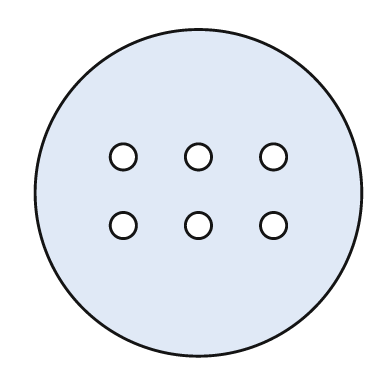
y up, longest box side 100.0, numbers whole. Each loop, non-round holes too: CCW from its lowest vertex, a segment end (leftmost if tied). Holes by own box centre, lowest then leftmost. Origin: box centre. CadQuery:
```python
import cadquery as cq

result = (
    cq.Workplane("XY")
    .moveTo(0.0, 0.0)
    .circle(50.0)
    .moveTo(-23.0, -10.0)
    .circle(4.0)
    .moveTo(0.0, -10.0)
    .circle(4.0)
    .moveTo(23.0, -10.0)
    .circle(4.0)
    .moveTo(-23.0, 11.0)
    .circle(4.0)
    .moveTo(0.0, 11.0)
    .circle(4.0)
    .moveTo(23.0, 11.0)
    .circle(4.0)
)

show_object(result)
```